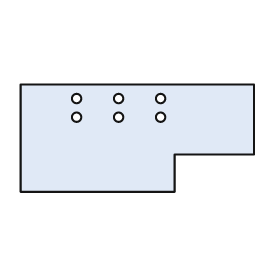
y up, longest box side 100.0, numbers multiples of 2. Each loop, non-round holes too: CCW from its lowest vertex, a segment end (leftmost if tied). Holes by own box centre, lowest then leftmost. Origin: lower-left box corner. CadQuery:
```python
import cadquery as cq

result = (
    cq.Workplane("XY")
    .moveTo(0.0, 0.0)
    .lineTo(66.0, 0.0)
    .lineTo(66.0, 16.0)
    .lineTo(100.0, 16.0)
    .lineTo(100.0, 46.0)
    .lineTo(0.0, 46.0)
    .close()
    .moveTo(24.0, 32.0)
    .circle(2.0)
    .moveTo(42.0, 32.0)
    .circle(2.0)
    .moveTo(60.0, 32.0)
    .circle(2.0)
    .moveTo(24.0, 40.0)
    .circle(2.0)
    .moveTo(42.0, 40.0)
    .circle(2.0)
    .moveTo(60.0, 40.0)
    .circle(2.0)
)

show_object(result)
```